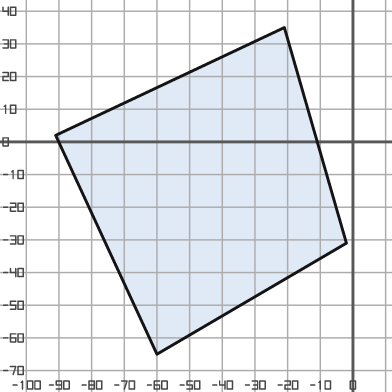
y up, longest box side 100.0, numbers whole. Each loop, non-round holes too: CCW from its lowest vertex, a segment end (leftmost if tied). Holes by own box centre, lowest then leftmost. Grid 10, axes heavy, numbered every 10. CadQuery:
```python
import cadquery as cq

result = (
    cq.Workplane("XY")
    .moveTo(-60.0, -65.0)
    .lineTo(-2.0, -31.0)
    .lineTo(-21.0, 35.0)
    .lineTo(-91.0, 2.0)
    .close()
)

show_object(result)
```